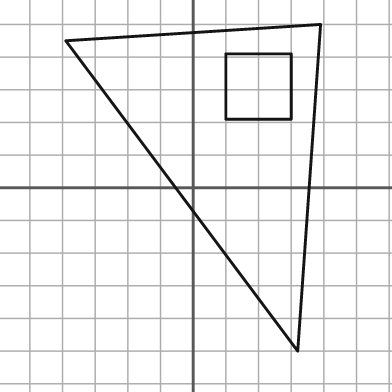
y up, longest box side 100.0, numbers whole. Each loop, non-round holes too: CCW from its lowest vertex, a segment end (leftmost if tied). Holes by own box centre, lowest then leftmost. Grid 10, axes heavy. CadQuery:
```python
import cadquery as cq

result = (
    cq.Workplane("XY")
    .moveTo(32.0, -50.0)
    .lineTo(39.0, 50.0)
    .lineTo(-39.0, 45.0)
    .close()
    .moveTo(10.0, 21.0)
    .lineTo(30.0, 21.0)
    .lineTo(30.0, 41.0)
    .lineTo(10.0, 41.0)
    .close()
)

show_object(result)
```